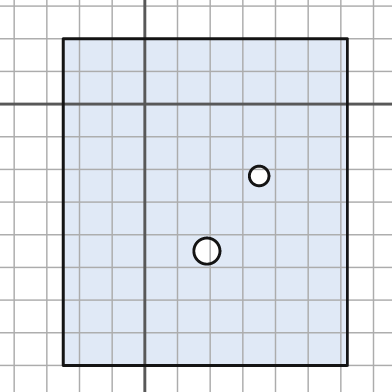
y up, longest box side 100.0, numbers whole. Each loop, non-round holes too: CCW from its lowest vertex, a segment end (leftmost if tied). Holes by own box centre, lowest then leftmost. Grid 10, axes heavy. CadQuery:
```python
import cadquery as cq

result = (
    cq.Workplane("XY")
    .moveTo(-25.0, -80.0)
    .lineTo(62.0, -80.0)
    .lineTo(62.0, 20.0)
    .lineTo(-25.0, 20.0)
    .close()
    .moveTo(19.0, -45.0)
    .circle(4.0)
    .moveTo(35.0, -22.0)
    .circle(3.0)
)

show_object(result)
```